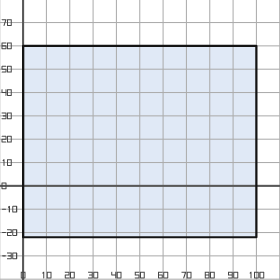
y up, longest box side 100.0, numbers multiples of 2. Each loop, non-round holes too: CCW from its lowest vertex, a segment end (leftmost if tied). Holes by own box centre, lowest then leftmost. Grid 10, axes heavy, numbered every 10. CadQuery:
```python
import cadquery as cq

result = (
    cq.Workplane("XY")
    .moveTo(0.0, -22.0)
    .lineTo(100.0, -22.0)
    .lineTo(100.0, 60.0)
    .lineTo(0.0, 60.0)
    .close()
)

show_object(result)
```